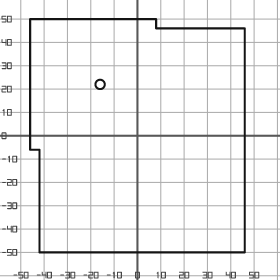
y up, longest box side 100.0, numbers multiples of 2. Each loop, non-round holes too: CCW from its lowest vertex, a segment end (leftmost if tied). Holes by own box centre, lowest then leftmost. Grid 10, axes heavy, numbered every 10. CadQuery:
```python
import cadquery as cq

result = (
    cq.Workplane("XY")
    .moveTo(-42.0, -50.0)
    .lineTo(46.0, -50.0)
    .lineTo(46.0, 46.0)
    .lineTo(8.0, 46.0)
    .lineTo(8.0, 50.0)
    .lineTo(-46.0, 50.0)
    .lineTo(-46.0, -6.0)
    .lineTo(-42.0, -6.0)
    .close()
    .moveTo(-16.0, 22.0)
    .circle(2.0)
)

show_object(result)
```